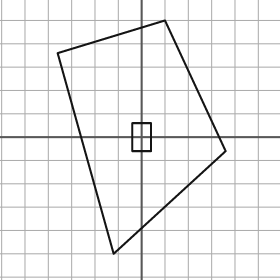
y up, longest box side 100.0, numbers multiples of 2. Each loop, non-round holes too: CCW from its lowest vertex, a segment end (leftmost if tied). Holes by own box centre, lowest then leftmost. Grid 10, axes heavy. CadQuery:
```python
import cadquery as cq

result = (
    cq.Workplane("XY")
    .moveTo(-12.0, -50.0)
    .lineTo(36.0, -6.0)
    .lineTo(10.0, 50.0)
    .lineTo(-36.0, 36.0)
    .close()
    .moveTo(-4.0, -6.0)
    .lineTo(4.0, -6.0)
    .lineTo(4.0, 6.0)
    .lineTo(-4.0, 6.0)
    .close()
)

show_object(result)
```